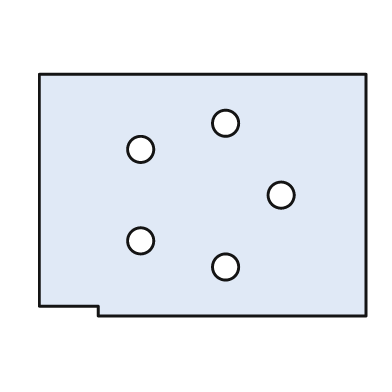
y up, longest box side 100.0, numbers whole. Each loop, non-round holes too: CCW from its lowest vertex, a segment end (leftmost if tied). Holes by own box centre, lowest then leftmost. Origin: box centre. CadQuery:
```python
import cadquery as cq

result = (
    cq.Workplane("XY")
    .moveTo(-32.0, -37.0)
    .lineTo(50.0, -37.0)
    .lineTo(50.0, 37.0)
    .lineTo(-50.0, 37.0)
    .lineTo(-50.0, -34.0)
    .lineTo(-32.0, -34.0)
    .close()
    .moveTo(7.0, -22.0)
    .circle(4.0)
    .moveTo(-19.0, -14.0)
    .circle(4.0)
    .moveTo(24.0, 0.0)
    .circle(4.0)
    .moveTo(-19.0, 14.0)
    .circle(4.0)
    .moveTo(7.0, 22.0)
    .circle(4.0)
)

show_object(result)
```